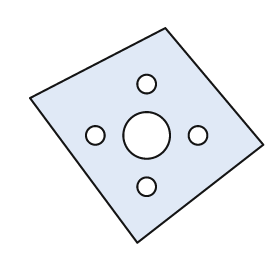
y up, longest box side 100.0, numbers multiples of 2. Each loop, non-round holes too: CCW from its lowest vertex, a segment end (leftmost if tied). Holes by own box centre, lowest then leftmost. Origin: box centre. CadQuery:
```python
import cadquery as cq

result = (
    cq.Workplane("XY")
    .moveTo(-4.0, -46.0)
    .lineTo(50.0, -4.0)
    .lineTo(8.0, 46.0)
    .lineTo(-50.0, 16.0)
    .close()
    .moveTo(0.0, -22.0)
    .circle(4.0)
    .moveTo(-22.0, 0.0)
    .circle(4.0)
    .moveTo(0.0, 0.0)
    .circle(10.0)
    .moveTo(22.0, 0.0)
    .circle(4.0)
    .moveTo(0.0, 22.0)
    .circle(4.0)
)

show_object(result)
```